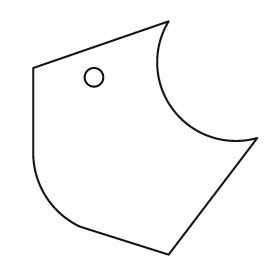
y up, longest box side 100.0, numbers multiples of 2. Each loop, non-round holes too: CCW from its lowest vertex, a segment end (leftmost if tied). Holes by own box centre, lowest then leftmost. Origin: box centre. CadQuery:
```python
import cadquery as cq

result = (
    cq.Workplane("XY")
    .moveTo(10.0, -50.0)
    .lineTo(48.0, 0.0)
    .threePointArc((12.0, 12.0), (10.0, 50.0))
    .lineTo(-48.0, 30.0)
    .lineTo(-48.0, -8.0)
    .threePointArc((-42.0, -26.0), (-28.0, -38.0))
    .close()
    .moveTo(-22.0, 26.0)
    .circle(4.0)
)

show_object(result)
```